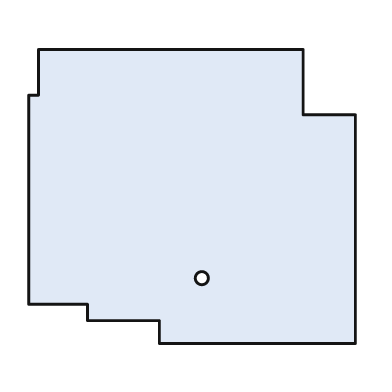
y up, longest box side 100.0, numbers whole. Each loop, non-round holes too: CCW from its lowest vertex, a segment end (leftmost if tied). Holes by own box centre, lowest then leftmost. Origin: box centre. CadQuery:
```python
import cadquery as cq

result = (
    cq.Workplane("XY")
    .moveTo(-10.0, -45.0)
    .lineTo(50.0, -45.0)
    .lineTo(50.0, 25.0)
    .lineTo(34.0, 25.0)
    .lineTo(34.0, 45.0)
    .lineTo(-47.0, 45.0)
    .lineTo(-47.0, 31.0)
    .lineTo(-50.0, 31.0)
    .lineTo(-50.0, -33.0)
    .lineTo(-32.0, -33.0)
    .lineTo(-32.0, -38.0)
    .lineTo(-10.0, -38.0)
    .close()
    .moveTo(3.0, -25.0)
    .circle(2.0)
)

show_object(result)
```